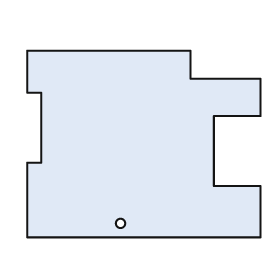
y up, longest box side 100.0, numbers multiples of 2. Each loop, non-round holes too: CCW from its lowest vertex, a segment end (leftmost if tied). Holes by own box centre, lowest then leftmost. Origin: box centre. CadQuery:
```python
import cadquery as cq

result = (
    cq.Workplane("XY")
    .moveTo(-50.0, -40.0)
    .lineTo(50.0, -40.0)
    .lineTo(50.0, -18.0)
    .lineTo(30.0, -18.0)
    .lineTo(30.0, 12.0)
    .lineTo(50.0, 12.0)
    .lineTo(50.0, 28.0)
    .lineTo(20.0, 28.0)
    .lineTo(20.0, 40.0)
    .lineTo(-50.0, 40.0)
    .lineTo(-50.0, 22.0)
    .lineTo(-44.0, 22.0)
    .lineTo(-44.0, -8.0)
    .lineTo(-50.0, -8.0)
    .close()
    .moveTo(-10.0, -34.0)
    .circle(2.0)
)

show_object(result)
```